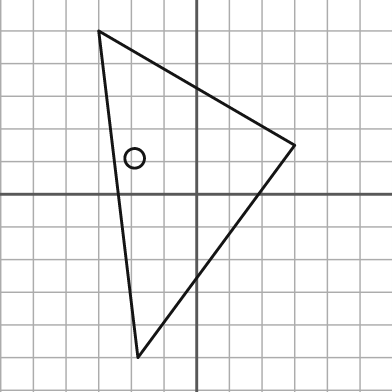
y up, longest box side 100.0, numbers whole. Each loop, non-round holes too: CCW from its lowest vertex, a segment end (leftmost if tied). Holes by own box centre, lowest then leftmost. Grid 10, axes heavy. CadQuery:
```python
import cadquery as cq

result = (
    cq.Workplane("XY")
    .moveTo(-18.0, -50.0)
    .lineTo(30.0, 15.0)
    .lineTo(-30.0, 50.0)
    .close()
    .moveTo(-19.0, 11.0)
    .circle(3.0)
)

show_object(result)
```